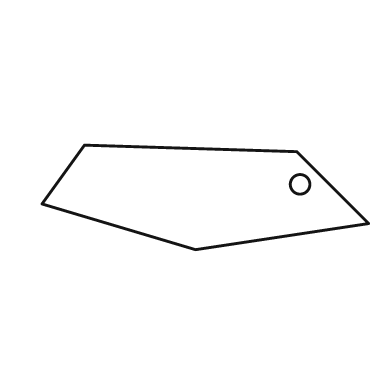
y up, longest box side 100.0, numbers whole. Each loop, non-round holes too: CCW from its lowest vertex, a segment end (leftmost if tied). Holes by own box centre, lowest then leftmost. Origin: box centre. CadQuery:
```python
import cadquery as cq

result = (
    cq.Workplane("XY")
    .moveTo(-3.0, -16.0)
    .lineTo(50.0, -8.0)
    .lineTo(28.0, 14.0)
    .lineTo(-37.0, 16.0)
    .lineTo(-50.0, -2.0)
    .close()
    .moveTo(29.0, 4.0)
    .circle(3.0)
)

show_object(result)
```